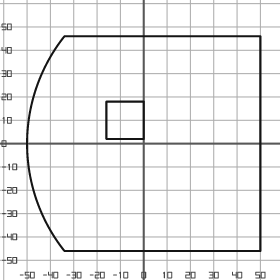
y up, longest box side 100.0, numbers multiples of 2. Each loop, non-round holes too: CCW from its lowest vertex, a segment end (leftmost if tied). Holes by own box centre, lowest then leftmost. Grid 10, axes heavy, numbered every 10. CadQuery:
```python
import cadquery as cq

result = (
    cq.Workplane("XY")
    .moveTo(-34.0, -46.0)
    .lineTo(50.0, -46.0)
    .lineTo(50.0, 46.0)
    .lineTo(-34.0, 46.0)
    .threePointArc((-50.0, 0.0), (-34.0, -46.0))
    .close()
    .moveTo(-16.0, 2.0)
    .lineTo(0.0, 2.0)
    .lineTo(0.0, 18.0)
    .lineTo(-16.0, 18.0)
    .close()
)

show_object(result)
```